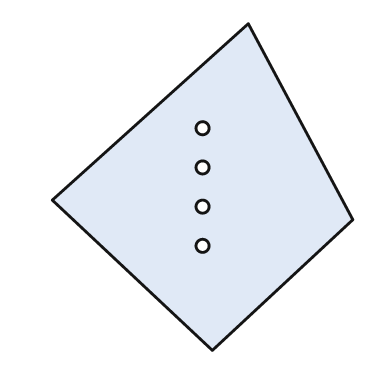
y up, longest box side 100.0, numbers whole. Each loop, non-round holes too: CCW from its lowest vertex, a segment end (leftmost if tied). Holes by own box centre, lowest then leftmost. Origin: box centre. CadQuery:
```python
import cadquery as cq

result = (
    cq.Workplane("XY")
    .moveTo(3.0, -50.0)
    .lineTo(46.0, -10.0)
    .lineTo(14.0, 50.0)
    .lineTo(-46.0, -4.0)
    .close()
    .moveTo(0.0, -18.0)
    .circle(2.0)
    .moveTo(0.0, -6.0)
    .circle(2.0)
    .moveTo(0.0, 6.0)
    .circle(2.0)
    .moveTo(0.0, 18.0)
    .circle(2.0)
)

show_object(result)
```